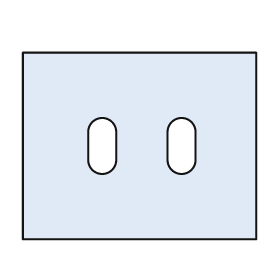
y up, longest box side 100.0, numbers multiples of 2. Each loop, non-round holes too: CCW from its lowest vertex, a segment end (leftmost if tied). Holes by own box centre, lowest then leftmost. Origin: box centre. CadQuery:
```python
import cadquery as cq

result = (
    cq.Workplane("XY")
    .moveTo(-50.0, -40.0)
    .lineTo(50.0, -40.0)
    .lineTo(50.0, 40.0)
    .lineTo(-50.0, 40.0)
    .close()
    .moveTo(-22.0, -6.0)
    .threePointArc((-16.0, -12.0), (-10.0, -6.0))
    .lineTo(-10.0, 6.0)
    .threePointArc((-16.0, 12.0), (-22.0, 6.0))
    .close()
    .moveTo(12.0, -6.0)
    .threePointArc((18.0, -12.0), (24.0, -6.0))
    .lineTo(24.0, 6.0)
    .threePointArc((18.0, 12.0), (12.0, 6.0))
    .close()
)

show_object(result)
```